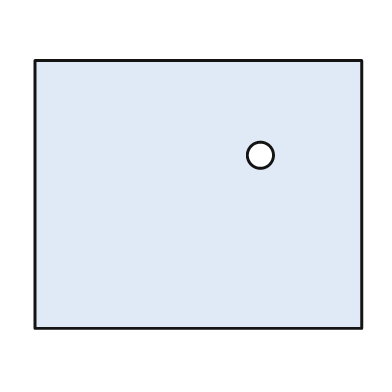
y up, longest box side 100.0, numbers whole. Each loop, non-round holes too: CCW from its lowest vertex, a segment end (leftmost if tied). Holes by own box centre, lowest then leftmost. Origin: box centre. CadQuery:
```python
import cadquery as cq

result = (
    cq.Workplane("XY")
    .moveTo(-50.0, -41.0)
    .lineTo(50.0, -41.0)
    .lineTo(50.0, 41.0)
    .lineTo(-50.0, 41.0)
    .close()
    .moveTo(19.0, 12.0)
    .circle(4.0)
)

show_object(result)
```